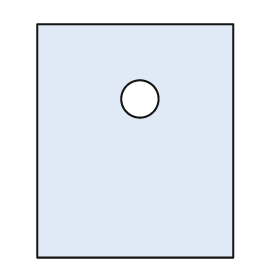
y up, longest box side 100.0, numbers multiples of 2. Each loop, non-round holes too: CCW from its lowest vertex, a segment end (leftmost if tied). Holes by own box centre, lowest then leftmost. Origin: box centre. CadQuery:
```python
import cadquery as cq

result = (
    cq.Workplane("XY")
    .moveTo(-42.0, -50.0)
    .lineTo(42.0, -50.0)
    .lineTo(42.0, 50.0)
    .lineTo(-42.0, 50.0)
    .close()
    .moveTo(2.0, 18.0)
    .circle(8.0)
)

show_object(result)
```